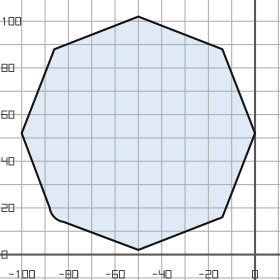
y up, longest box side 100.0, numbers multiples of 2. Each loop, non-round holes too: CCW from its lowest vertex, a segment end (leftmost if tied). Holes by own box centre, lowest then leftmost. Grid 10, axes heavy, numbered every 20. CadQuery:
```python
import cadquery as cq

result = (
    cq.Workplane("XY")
    .moveTo(-50.0, 2.0)
    .lineTo(-14.0, 16.0)
    .lineTo(0.0, 52.0)
    .lineTo(-14.0, 88.0)
    .lineTo(-50.0, 102.0)
    .lineTo(-86.0, 88.0)
    .lineTo(-100.0, 52.0)
    .lineTo(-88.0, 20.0)
    .threePointArc((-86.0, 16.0), (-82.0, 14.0))
    .close()
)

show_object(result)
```